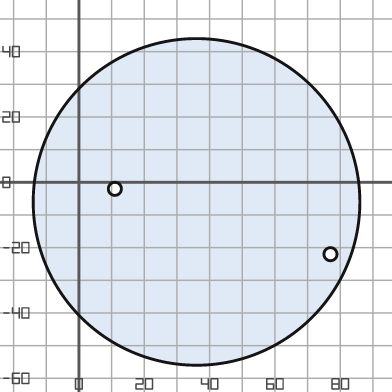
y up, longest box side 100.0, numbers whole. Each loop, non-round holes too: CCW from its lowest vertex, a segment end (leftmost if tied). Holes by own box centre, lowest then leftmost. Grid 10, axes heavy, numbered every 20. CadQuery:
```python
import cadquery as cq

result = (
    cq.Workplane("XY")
    .moveTo(36.0, -6.0)
    .circle(50.0)
    .moveTo(77.0, -22.0)
    .circle(2.0)
    .moveTo(11.0, -2.0)
    .circle(2.0)
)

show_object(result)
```